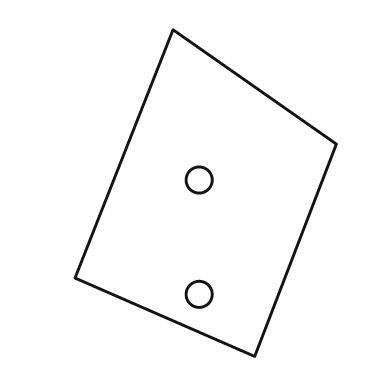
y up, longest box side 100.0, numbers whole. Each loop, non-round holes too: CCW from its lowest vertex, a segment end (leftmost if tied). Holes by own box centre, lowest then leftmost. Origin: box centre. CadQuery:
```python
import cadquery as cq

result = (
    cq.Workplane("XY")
    .moveTo(15.0, -50.0)
    .lineTo(40.0, 15.0)
    .lineTo(-10.0, 50.0)
    .lineTo(-40.0, -26.0)
    .close()
    .moveTo(-2.0, -31.0)
    .circle(4.0)
    .moveTo(-2.0, 4.0)
    .circle(4.0)
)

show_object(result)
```